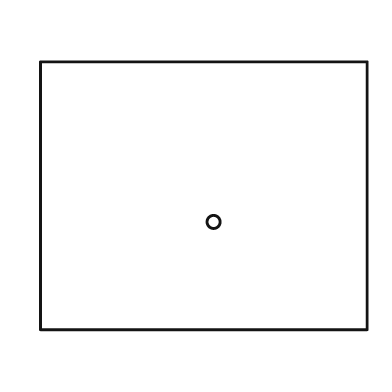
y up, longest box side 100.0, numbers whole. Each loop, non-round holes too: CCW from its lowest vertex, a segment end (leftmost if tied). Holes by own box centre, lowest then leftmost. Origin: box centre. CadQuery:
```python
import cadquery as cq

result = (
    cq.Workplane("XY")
    .moveTo(-50.0, -41.0)
    .lineTo(50.0, -41.0)
    .lineTo(50.0, 41.0)
    .lineTo(-50.0, 41.0)
    .close()
    .moveTo(3.0, -8.0)
    .circle(2.0)
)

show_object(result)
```